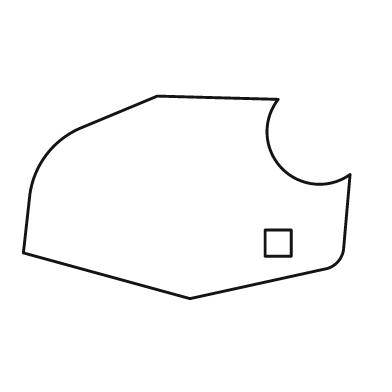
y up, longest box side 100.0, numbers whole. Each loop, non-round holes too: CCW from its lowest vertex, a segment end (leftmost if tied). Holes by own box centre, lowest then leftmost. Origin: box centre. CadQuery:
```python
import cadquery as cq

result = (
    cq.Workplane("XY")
    .moveTo(1.0, -31.0)
    .lineTo(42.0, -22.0)
    .threePointArc((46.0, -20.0), (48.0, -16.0))
    .lineTo(50.0, 7.0)
    .threePointArc((29.0, 9.0), (28.0, 30.0))
    .lineTo(-9.0, 31.0)
    .lineTo(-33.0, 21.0)
    .threePointArc((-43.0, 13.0), (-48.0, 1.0))
    .lineTo(-50.0, -17.0)
    .close()
    .moveTo(24.0, -18.0)
    .lineTo(32.0, -18.0)
    .lineTo(32.0, -10.0)
    .lineTo(24.0, -10.0)
    .close()
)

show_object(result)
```